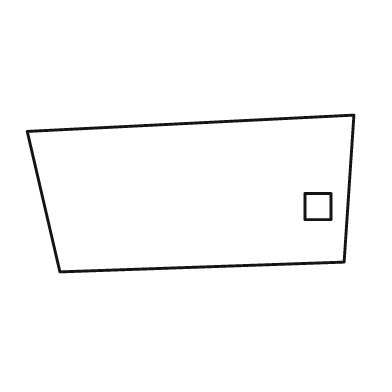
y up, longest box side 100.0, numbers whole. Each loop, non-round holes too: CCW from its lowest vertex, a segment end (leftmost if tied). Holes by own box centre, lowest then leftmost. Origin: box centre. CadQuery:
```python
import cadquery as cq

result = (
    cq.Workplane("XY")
    .moveTo(-40.0, -24.0)
    .lineTo(47.0, -21.0)
    .lineTo(50.0, 24.0)
    .lineTo(-50.0, 19.0)
    .close()
    .moveTo(35.0, -8.0)
    .lineTo(43.0, -8.0)
    .lineTo(43.0, 0.0)
    .lineTo(35.0, 0.0)
    .close()
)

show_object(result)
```